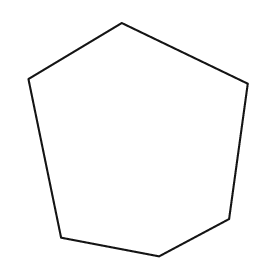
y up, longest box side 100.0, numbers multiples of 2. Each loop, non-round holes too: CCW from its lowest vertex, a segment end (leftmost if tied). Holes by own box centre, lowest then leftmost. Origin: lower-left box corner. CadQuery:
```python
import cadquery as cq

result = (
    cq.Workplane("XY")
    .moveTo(56.0, 0.0)
    .lineTo(86.0, 16.0)
    .lineTo(94.0, 74.0)
    .lineTo(40.0, 100.0)
    .lineTo(0.0, 76.0)
    .lineTo(14.0, 8.0)
    .close()
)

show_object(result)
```